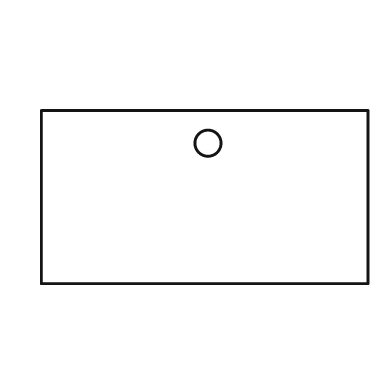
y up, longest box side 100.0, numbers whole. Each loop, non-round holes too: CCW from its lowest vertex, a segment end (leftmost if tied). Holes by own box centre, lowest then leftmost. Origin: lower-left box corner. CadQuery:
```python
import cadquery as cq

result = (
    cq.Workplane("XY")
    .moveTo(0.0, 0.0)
    .lineTo(100.0, 0.0)
    .lineTo(100.0, 53.0)
    .lineTo(0.0, 53.0)
    .close()
    .moveTo(51.0, 43.0)
    .circle(4.0)
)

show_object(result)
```